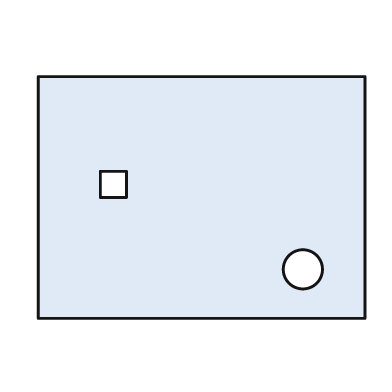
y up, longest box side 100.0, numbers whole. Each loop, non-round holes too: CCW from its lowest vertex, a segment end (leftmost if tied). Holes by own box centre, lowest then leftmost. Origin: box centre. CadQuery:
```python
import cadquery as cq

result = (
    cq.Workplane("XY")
    .moveTo(-50.0, -37.0)
    .lineTo(50.0, -37.0)
    .lineTo(50.0, 37.0)
    .lineTo(-50.0, 37.0)
    .close()
    .moveTo(31.0, -22.0)
    .circle(6.0)
    .moveTo(-31.0, 0.0)
    .lineTo(-23.0, 0.0)
    .lineTo(-23.0, 8.0)
    .lineTo(-31.0, 8.0)
    .close()
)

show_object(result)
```